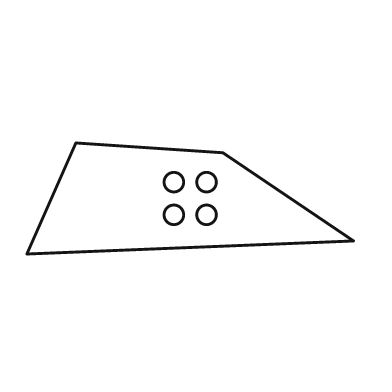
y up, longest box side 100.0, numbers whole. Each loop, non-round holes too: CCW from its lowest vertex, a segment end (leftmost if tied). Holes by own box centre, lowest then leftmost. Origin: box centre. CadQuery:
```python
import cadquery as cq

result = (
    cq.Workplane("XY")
    .moveTo(-50.0, -17.0)
    .lineTo(50.0, -13.0)
    .lineTo(10.0, 14.0)
    .lineTo(-35.0, 17.0)
    .close()
    .moveTo(-5.0, -5.0)
    .circle(3.0)
    .moveTo(5.0, -5.0)
    .circle(3.0)
    .moveTo(-5.0, 5.0)
    .circle(3.0)
    .moveTo(5.0, 5.0)
    .circle(3.0)
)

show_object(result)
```